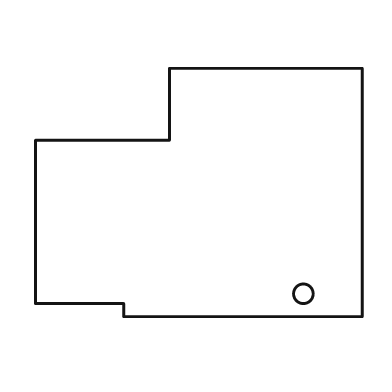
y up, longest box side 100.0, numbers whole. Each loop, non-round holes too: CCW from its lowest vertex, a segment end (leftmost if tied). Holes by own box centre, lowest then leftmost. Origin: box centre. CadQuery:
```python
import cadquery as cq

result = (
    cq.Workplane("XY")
    .moveTo(-23.0, -38.0)
    .lineTo(50.0, -38.0)
    .lineTo(50.0, 38.0)
    .lineTo(-9.0, 38.0)
    .lineTo(-9.0, 16.0)
    .lineTo(-50.0, 16.0)
    .lineTo(-50.0, -34.0)
    .lineTo(-23.0, -34.0)
    .close()
    .moveTo(32.0, -31.0)
    .circle(3.0)
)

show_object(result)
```